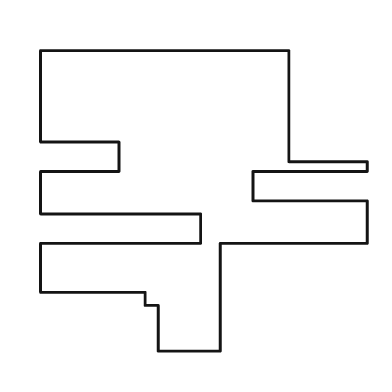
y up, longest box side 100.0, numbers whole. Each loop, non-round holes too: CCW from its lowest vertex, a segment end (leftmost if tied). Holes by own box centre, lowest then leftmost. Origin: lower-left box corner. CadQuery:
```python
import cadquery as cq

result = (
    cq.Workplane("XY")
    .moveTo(36.0, 0.0)
    .lineTo(55.0, 0.0)
    .lineTo(55.0, 33.0)
    .lineTo(100.0, 33.0)
    .lineTo(100.0, 46.0)
    .lineTo(65.0, 46.0)
    .lineTo(65.0, 55.0)
    .lineTo(100.0, 55.0)
    .lineTo(100.0, 58.0)
    .lineTo(76.0, 58.0)
    .lineTo(76.0, 92.0)
    .lineTo(0.0, 92.0)
    .lineTo(0.0, 64.0)
    .lineTo(24.0, 64.0)
    .lineTo(24.0, 55.0)
    .lineTo(0.0, 55.0)
    .lineTo(0.0, 42.0)
    .lineTo(49.0, 42.0)
    .lineTo(49.0, 33.0)
    .lineTo(0.0, 33.0)
    .lineTo(0.0, 18.0)
    .lineTo(32.0, 18.0)
    .lineTo(32.0, 14.0)
    .lineTo(36.0, 14.0)
    .close()
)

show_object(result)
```